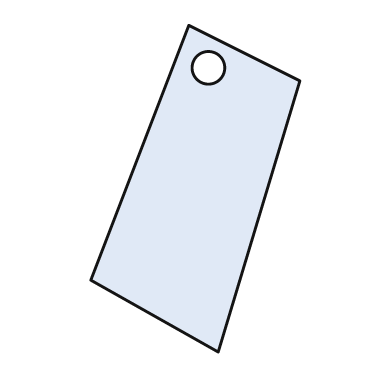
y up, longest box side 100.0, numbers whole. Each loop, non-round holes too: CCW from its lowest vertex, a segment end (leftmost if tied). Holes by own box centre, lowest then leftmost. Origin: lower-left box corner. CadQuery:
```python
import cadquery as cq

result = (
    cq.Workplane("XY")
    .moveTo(39.0, 0.0)
    .lineTo(64.0, 83.0)
    .lineTo(30.0, 100.0)
    .lineTo(0.0, 22.0)
    .close()
    .moveTo(36.0, 87.0)
    .circle(5.0)
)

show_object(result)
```